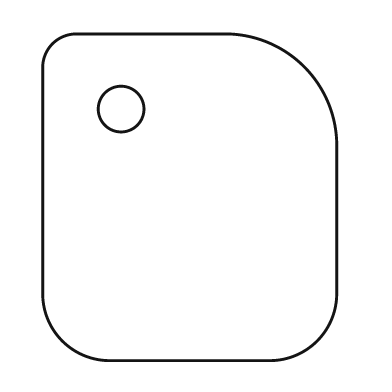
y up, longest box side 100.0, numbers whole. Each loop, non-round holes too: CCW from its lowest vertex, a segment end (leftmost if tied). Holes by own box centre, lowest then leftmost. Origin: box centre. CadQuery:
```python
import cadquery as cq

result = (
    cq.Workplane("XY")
    .moveTo(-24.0, -50.0)
    .lineTo(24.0, -50.0)
    .threePointArc((39.0, -44.0), (45.0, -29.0))
    .lineTo(45.0, 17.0)
    .threePointArc((35.0, 40.0), (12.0, 50.0))
    .lineTo(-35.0, 50.0)
    .threePointArc((-42.0, 47.0), (-45.0, 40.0))
    .lineTo(-45.0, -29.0)
    .threePointArc((-39.0, -44.0), (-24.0, -50.0))
    .close()
    .moveTo(-21.0, 27.0)
    .circle(7.0)
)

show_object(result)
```